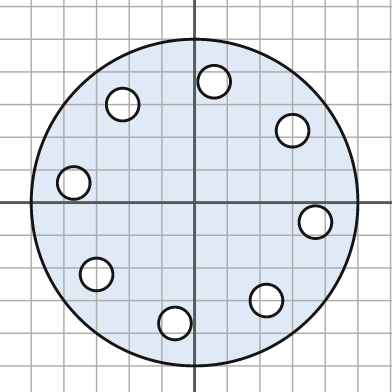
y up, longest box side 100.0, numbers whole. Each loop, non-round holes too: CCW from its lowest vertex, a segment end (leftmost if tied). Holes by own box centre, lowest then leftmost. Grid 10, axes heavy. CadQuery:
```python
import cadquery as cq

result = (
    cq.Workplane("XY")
    .moveTo(0.0, 0.0)
    .circle(50.0)
    .moveTo(-6.0, -37.0)
    .circle(5.0)
    .moveTo(22.0, -30.0)
    .circle(5.0)
    .moveTo(-30.0, -22.0)
    .circle(5.0)
    .moveTo(37.0, -6.0)
    .circle(5.0)
    .moveTo(-37.0, 6.0)
    .circle(5.0)
    .moveTo(30.0, 22.0)
    .circle(5.0)
    .moveTo(-22.0, 30.0)
    .circle(5.0)
    .moveTo(6.0, 37.0)
    .circle(5.0)
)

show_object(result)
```